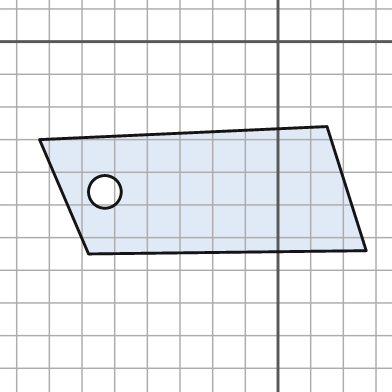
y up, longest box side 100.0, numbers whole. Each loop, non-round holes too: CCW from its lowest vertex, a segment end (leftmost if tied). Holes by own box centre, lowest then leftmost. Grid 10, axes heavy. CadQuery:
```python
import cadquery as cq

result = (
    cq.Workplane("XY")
    .moveTo(-58.0, -65.0)
    .lineTo(27.0, -64.0)
    .lineTo(15.0, -26.0)
    .lineTo(-73.0, -30.0)
    .close()
    .moveTo(-53.0, -46.0)
    .circle(5.0)
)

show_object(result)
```